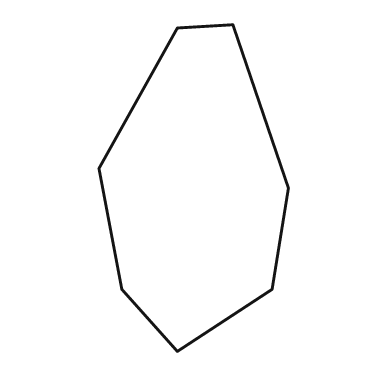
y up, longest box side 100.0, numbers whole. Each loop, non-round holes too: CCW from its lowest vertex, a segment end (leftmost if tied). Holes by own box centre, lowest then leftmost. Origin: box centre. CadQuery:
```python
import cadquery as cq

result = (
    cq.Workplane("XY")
    .moveTo(-5.0, -50.0)
    .lineTo(24.0, -31.0)
    .lineTo(29.0, 0.0)
    .lineTo(12.0, 50.0)
    .lineTo(-5.0, 49.0)
    .lineTo(-29.0, 6.0)
    .lineTo(-22.0, -31.0)
    .close()
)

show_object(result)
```